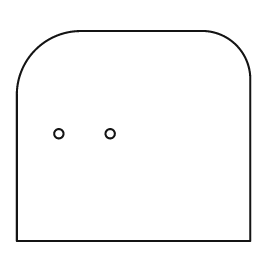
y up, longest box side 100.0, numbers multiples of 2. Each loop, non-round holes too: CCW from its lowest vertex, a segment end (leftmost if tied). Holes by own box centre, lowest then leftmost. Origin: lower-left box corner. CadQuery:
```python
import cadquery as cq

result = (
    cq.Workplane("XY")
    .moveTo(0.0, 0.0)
    .lineTo(100.0, 0.0)
    .lineTo(100.0, 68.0)
    .threePointArc((94.0, 84.0), (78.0, 90.0))
    .lineTo(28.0, 90.0)
    .threePointArc((8.0, 82.0), (0.0, 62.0))
    .close()
    .moveTo(18.0, 46.0)
    .circle(2.0)
    .moveTo(40.0, 46.0)
    .circle(2.0)
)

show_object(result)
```